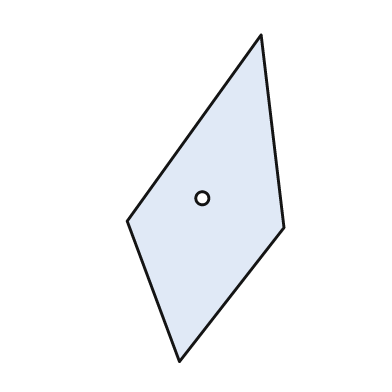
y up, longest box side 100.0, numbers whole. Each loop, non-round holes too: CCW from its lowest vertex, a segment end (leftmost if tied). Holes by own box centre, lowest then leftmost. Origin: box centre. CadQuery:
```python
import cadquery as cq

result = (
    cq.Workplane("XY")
    .moveTo(-8.0, -50.0)
    .lineTo(24.0, -9.0)
    .lineTo(17.0, 50.0)
    .lineTo(-24.0, -7.0)
    .close()
    .moveTo(-1.0, 0.0)
    .circle(2.0)
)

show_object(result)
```